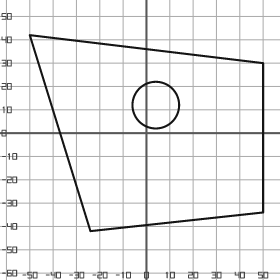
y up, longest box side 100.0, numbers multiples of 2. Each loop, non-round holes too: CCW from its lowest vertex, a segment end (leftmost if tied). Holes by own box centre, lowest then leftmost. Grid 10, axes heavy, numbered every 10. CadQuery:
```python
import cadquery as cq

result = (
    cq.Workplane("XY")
    .moveTo(-24.0, -42.0)
    .lineTo(50.0, -34.0)
    .lineTo(50.0, 30.0)
    .lineTo(-50.0, 42.0)
    .close()
    .moveTo(4.0, 12.0)
    .circle(10.0)
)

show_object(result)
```